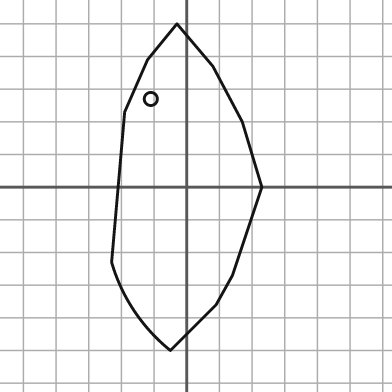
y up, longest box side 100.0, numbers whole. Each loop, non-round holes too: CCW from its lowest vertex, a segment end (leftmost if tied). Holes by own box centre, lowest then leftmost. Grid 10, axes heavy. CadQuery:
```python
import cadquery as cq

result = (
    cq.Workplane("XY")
    .moveTo(-5.0, -50.0)
    .lineTo(9.0, -36.0)
    .lineTo(14.0, -27.0)
    .lineTo(23.0, 0.0)
    .lineTo(17.0, 20.0)
    .lineTo(8.0, 37.0)
    .lineTo(-3.0, 50.0)
    .lineTo(-12.0, 39.0)
    .lineTo(-19.0, 23.0)
    .lineTo(-23.0, -23.0)
    .threePointArc((-16.0, -38.0), (-5.0, -50.0))
    .close()
    .moveTo(-11.0, 27.0)
    .circle(2.0)
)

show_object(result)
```